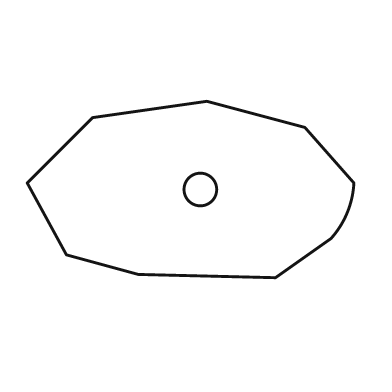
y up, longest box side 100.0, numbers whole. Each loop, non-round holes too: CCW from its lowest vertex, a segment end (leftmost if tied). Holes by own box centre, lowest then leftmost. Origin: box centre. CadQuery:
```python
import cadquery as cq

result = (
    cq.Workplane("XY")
    .moveTo(26.0, -27.0)
    .lineTo(43.0, -15.0)
    .threePointArc((48.0, -7.0), (50.0, 2.0))
    .lineTo(35.0, 19.0)
    .lineTo(5.0, 27.0)
    .lineTo(-30.0, 22.0)
    .lineTo(-50.0, 2.0)
    .lineTo(-38.0, -20.0)
    .lineTo(-16.0, -26.0)
    .close()
    .moveTo(3.0, 0.0)
    .circle(5.0)
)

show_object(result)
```